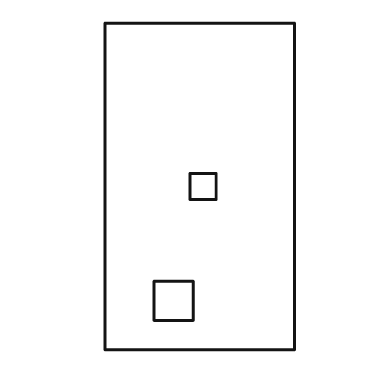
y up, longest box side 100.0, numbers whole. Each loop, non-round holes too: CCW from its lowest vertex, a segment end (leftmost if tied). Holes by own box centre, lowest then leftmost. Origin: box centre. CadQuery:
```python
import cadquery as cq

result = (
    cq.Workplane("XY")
    .moveTo(-29.0, -50.0)
    .lineTo(29.0, -50.0)
    .lineTo(29.0, 50.0)
    .lineTo(-29.0, 50.0)
    .close()
    .moveTo(-14.0, -41.0)
    .lineTo(-2.0, -41.0)
    .lineTo(-2.0, -29.0)
    .lineTo(-14.0, -29.0)
    .close()
    .moveTo(-3.0, -4.0)
    .lineTo(5.0, -4.0)
    .lineTo(5.0, 4.0)
    .lineTo(-3.0, 4.0)
    .close()
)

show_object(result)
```